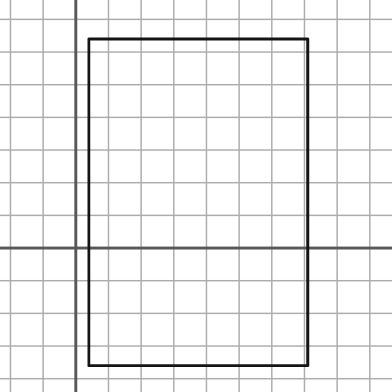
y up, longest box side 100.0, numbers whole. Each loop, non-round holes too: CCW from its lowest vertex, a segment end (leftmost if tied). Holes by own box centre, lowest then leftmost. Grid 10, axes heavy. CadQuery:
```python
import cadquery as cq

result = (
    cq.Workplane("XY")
    .moveTo(4.0, -36.0)
    .lineTo(71.0, -36.0)
    .lineTo(71.0, 64.0)
    .lineTo(4.0, 64.0)
    .close()
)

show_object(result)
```